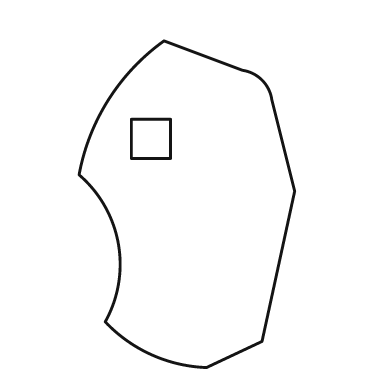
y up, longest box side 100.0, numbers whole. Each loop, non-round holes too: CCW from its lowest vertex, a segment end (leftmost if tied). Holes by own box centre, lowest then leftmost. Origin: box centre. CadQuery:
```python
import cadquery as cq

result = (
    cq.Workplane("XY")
    .moveTo(6.0, -50.0)
    .lineTo(23.0, -42.0)
    .lineTo(33.0, 4.0)
    .lineTo(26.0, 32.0)
    .threePointArc((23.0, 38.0), (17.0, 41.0))
    .lineTo(-7.0, 50.0)
    .threePointArc((-24.0, 32.0), (-33.0, 9.0))
    .threePointArc((-21.0, -12.0), (-25.0, -36.0))
    .threePointArc((-11.0, -46.0), (6.0, -50.0))
    .close()
    .moveTo(-17.0, 14.0)
    .lineTo(-5.0, 14.0)
    .lineTo(-5.0, 26.0)
    .lineTo(-17.0, 26.0)
    .close()
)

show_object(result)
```